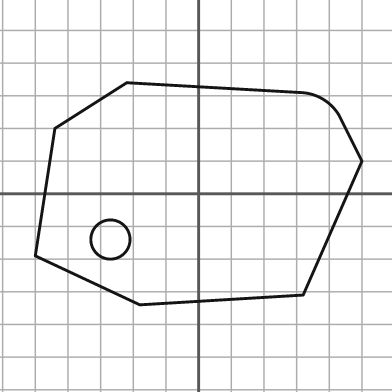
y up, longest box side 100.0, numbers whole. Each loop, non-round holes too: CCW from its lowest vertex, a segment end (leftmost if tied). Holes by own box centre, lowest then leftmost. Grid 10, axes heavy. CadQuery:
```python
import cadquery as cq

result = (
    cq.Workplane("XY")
    .moveTo(-18.0, -34.0)
    .lineTo(32.0, -31.0)
    .lineTo(50.0, 10.0)
    .lineTo(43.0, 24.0)
    .threePointArc((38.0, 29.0), (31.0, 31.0))
    .lineTo(-22.0, 34.0)
    .lineTo(-44.0, 20.0)
    .lineTo(-50.0, -19.0)
    .close()
    .moveTo(-27.0, -14.0)
    .circle(6.0)
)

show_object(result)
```